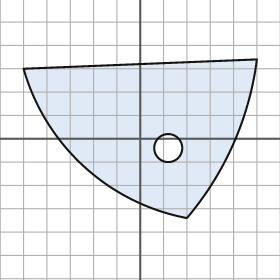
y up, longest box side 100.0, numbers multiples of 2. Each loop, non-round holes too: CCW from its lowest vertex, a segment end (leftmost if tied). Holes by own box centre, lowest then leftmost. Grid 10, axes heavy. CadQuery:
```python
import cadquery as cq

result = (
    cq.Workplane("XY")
    .moveTo(20.0, -34.0)
    .threePointArc((40.0, -2.0), (50.0, 34.0))
    .lineTo(-50.0, 30.0)
    .threePointArc((-24.0, -12.0), (20.0, -34.0))
    .close()
    .moveTo(12.0, -4.0)
    .circle(6.0)
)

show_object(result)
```